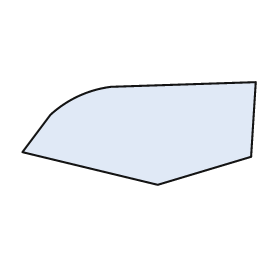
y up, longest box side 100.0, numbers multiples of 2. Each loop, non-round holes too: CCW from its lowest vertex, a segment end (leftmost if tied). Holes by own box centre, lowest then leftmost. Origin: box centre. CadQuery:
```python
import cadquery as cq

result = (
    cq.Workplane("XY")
    .moveTo(8.0, -22.0)
    .lineTo(48.0, -10.0)
    .lineTo(50.0, 22.0)
    .lineTo(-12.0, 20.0)
    .threePointArc((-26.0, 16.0), (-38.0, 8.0))
    .lineTo(-50.0, -8.0)
    .close()
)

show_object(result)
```